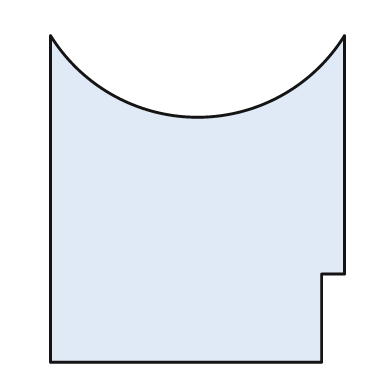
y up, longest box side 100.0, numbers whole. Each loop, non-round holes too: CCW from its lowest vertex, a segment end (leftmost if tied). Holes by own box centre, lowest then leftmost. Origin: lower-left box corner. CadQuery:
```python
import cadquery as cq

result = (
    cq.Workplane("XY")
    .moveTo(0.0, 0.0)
    .lineTo(83.0, 0.0)
    .lineTo(83.0, 27.0)
    .lineTo(90.0, 27.0)
    .lineTo(90.0, 100.0)
    .threePointArc((45.0, 75.0), (0.0, 100.0))
    .close()
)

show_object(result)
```